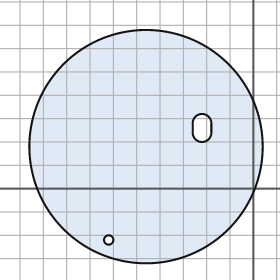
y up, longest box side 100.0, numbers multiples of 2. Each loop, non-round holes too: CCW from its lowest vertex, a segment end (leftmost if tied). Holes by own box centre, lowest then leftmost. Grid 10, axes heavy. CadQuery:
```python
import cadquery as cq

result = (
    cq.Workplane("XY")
    .moveTo(-46.0, 18.0)
    .circle(50.0)
    .moveTo(-62.0, -22.0)
    .circle(2.0)
    .moveTo(-26.0, 24.0)
    .threePointArc((-22.0, 20.0), (-18.0, 24.0))
    .lineTo(-18.0, 28.0)
    .threePointArc((-22.0, 32.0), (-26.0, 28.0))
    .close()
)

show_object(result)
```